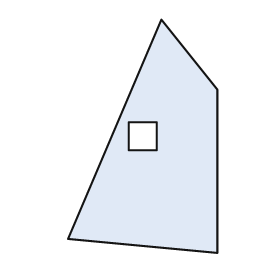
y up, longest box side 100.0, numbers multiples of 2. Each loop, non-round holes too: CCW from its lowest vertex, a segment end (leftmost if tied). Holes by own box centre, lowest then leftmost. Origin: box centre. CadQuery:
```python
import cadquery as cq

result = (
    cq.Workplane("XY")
    .moveTo(32.0, -50.0)
    .lineTo(32.0, 20.0)
    .lineTo(8.0, 50.0)
    .lineTo(-32.0, -44.0)
    .close()
    .moveTo(-6.0, -6.0)
    .lineTo(6.0, -6.0)
    .lineTo(6.0, 6.0)
    .lineTo(-6.0, 6.0)
    .close()
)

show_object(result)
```